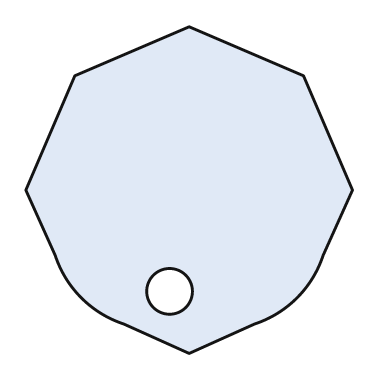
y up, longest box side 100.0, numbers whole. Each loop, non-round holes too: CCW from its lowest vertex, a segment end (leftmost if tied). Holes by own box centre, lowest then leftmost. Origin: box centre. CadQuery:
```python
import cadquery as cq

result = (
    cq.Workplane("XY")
    .moveTo(0.0, -50.0)
    .lineTo(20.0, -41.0)
    .threePointArc((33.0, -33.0), (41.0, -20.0))
    .lineTo(50.0, 0.0)
    .lineTo(35.0, 35.0)
    .lineTo(0.0, 50.0)
    .lineTo(-35.0, 35.0)
    .lineTo(-50.0, 0.0)
    .lineTo(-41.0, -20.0)
    .threePointArc((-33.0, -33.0), (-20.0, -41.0))
    .close()
    .moveTo(-6.0, -31.0)
    .circle(7.0)
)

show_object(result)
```